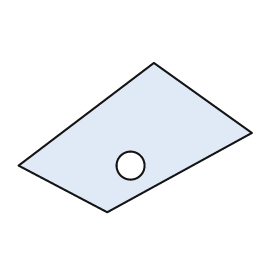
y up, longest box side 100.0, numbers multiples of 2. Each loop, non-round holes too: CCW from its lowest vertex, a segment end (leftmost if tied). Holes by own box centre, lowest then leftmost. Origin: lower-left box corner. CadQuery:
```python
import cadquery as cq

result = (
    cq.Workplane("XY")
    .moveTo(38.0, 0.0)
    .lineTo(100.0, 34.0)
    .lineTo(58.0, 64.0)
    .lineTo(0.0, 20.0)
    .close()
    .moveTo(48.0, 20.0)
    .circle(6.0)
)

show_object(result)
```